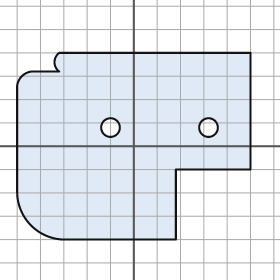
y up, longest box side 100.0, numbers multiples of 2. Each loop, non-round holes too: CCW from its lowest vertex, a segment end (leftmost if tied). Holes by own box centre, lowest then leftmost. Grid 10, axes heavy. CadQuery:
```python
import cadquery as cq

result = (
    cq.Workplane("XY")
    .moveTo(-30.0, -40.0)
    .lineTo(18.0, -40.0)
    .lineTo(18.0, -10.0)
    .lineTo(50.0, -10.0)
    .lineTo(50.0, 40.0)
    .lineTo(-32.0, 40.0)
    .threePointArc((-34.0, 36.0), (-32.0, 32.0))
    .lineTo(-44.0, 32.0)
    .threePointArc((-48.0, 30.0), (-50.0, 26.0))
    .lineTo(-50.0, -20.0)
    .threePointArc((-44.0, -34.0), (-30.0, -40.0))
    .close()
    .moveTo(-10.0, 8.0)
    .circle(4.0)
    .moveTo(32.0, 8.0)
    .circle(4.0)
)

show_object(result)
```